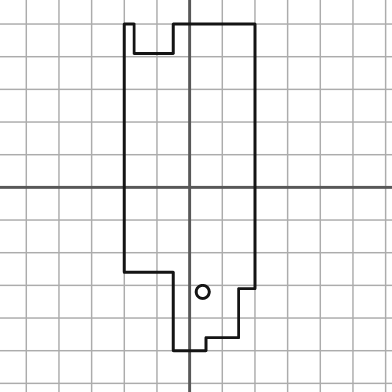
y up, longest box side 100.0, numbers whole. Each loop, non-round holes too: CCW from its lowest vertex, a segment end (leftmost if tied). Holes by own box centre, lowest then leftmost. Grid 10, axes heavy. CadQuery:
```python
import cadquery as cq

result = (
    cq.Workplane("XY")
    .moveTo(-5.0, -50.0)
    .lineTo(5.0, -50.0)
    .lineTo(5.0, -46.0)
    .lineTo(15.0, -46.0)
    .lineTo(15.0, -31.0)
    .lineTo(20.0, -31.0)
    .lineTo(20.0, 50.0)
    .lineTo(-5.0, 50.0)
    .lineTo(-5.0, 41.0)
    .lineTo(-17.0, 41.0)
    .lineTo(-17.0, 50.0)
    .lineTo(-20.0, 50.0)
    .lineTo(-20.0, -26.0)
    .lineTo(-5.0, -26.0)
    .close()
    .moveTo(4.0, -32.0)
    .circle(2.0)
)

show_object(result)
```